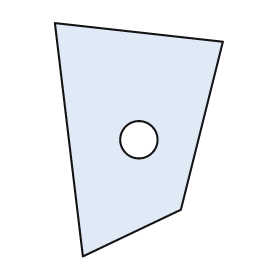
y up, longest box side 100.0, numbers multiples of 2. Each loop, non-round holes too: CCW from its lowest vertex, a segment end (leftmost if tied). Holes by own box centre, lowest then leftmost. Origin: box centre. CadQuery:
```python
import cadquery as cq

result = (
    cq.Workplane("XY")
    .moveTo(-24.0, -50.0)
    .lineTo(18.0, -30.0)
    .lineTo(36.0, 42.0)
    .lineTo(-36.0, 50.0)
    .close()
    .moveTo(0.0, 0.0)
    .circle(8.0)
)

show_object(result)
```